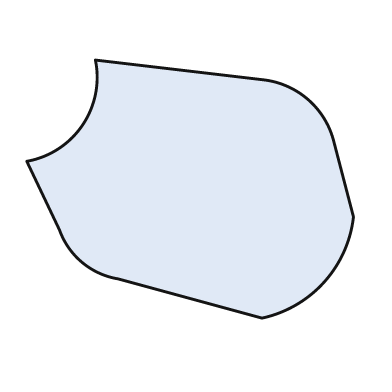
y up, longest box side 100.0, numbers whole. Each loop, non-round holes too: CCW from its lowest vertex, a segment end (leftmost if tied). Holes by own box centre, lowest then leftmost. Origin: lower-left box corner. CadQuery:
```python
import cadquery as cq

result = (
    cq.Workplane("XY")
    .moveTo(72.0, 0.0)
    .threePointArc((91.0, 11.0), (100.0, 31.0))
    .lineTo(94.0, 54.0)
    .threePointArc((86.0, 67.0), (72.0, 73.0))
    .lineTo(21.0, 79.0)
    .threePointArc((17.0, 59.0), (0.0, 48.0))
    .lineTo(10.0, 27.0)
    .threePointArc((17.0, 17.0), (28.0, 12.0))
    .close()
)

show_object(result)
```